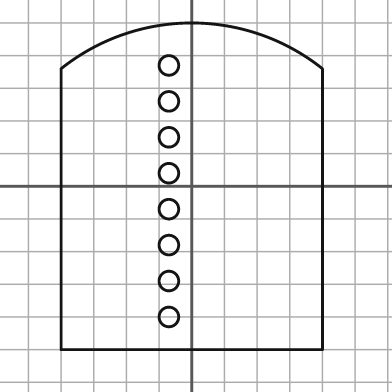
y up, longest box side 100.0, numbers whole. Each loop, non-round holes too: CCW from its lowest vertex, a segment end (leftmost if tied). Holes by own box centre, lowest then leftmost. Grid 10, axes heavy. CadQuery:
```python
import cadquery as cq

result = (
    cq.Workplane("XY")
    .moveTo(-40.0, -50.0)
    .lineTo(40.0, -50.0)
    .lineTo(40.0, 36.0)
    .threePointArc((0.0, 50.0), (-40.0, 36.0))
    .close()
    .moveTo(-7.0, -40.0)
    .circle(3.0)
    .moveTo(-7.0, -29.0)
    .circle(3.0)
    .moveTo(-7.0, -18.0)
    .circle(3.0)
    .moveTo(-7.0, -7.0)
    .circle(3.0)
    .moveTo(-7.0, 4.0)
    .circle(3.0)
    .moveTo(-7.0, 15.0)
    .circle(3.0)
    .moveTo(-7.0, 26.0)
    .circle(3.0)
    .moveTo(-7.0, 37.0)
    .circle(3.0)
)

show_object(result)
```